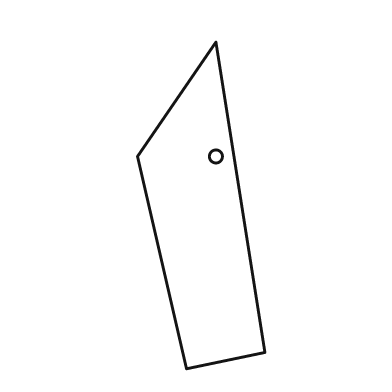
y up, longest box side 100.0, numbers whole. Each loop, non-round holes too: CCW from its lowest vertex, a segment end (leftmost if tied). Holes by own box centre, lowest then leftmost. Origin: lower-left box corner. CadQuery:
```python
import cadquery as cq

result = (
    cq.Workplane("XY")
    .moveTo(15.0, 0.0)
    .lineTo(39.0, 5.0)
    .lineTo(24.0, 100.0)
    .lineTo(0.0, 65.0)
    .close()
    .moveTo(24.0, 65.0)
    .circle(2.0)
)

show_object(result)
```